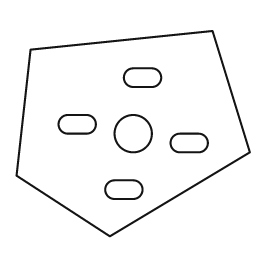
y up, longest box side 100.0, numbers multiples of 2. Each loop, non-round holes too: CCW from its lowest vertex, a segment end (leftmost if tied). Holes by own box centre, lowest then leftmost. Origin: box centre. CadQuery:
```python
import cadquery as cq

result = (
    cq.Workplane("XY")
    .moveTo(-10.0, -44.0)
    .lineTo(50.0, -8.0)
    .lineTo(34.0, 44.0)
    .lineTo(-44.0, 36.0)
    .lineTo(-50.0, -18.0)
    .close()
    .moveTo(-8.0, -28.0)
    .lineTo(0.0, -28.0)
    .threePointArc((4.0, -24.0), (0.0, -20.0))
    .lineTo(-8.0, -20.0)
    .threePointArc((-12.0, -24.0), (-8.0, -28.0))
    .close()
    .moveTo(20.0, -8.0)
    .lineTo(28.0, -8.0)
    .threePointArc((32.0, -4.0), (28.0, 0.0))
    .lineTo(20.0, 0.0)
    .threePointArc((16.0, -4.0), (20.0, -8.0))
    .close()
    .moveTo(0.0, 0.0)
    .circle(8.0)
    .moveTo(-28.0, 0.0)
    .lineTo(-20.0, 0.0)
    .threePointArc((-16.0, 4.0), (-20.0, 8.0))
    .lineTo(-28.0, 8.0)
    .threePointArc((-32.0, 4.0), (-28.0, 0.0))
    .close()
    .moveTo(0.0, 20.0)
    .lineTo(8.0, 20.0)
    .threePointArc((12.0, 24.0), (8.0, 28.0))
    .lineTo(0.0, 28.0)
    .threePointArc((-4.0, 24.0), (0.0, 20.0))
    .close()
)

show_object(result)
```